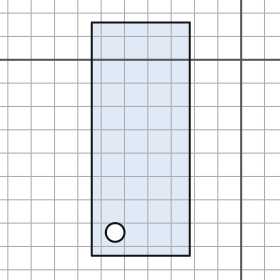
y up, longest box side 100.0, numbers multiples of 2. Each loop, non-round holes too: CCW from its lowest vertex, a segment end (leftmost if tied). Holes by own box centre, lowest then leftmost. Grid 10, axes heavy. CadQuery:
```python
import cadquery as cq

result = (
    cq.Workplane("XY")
    .moveTo(-64.0, -84.0)
    .lineTo(-22.0, -84.0)
    .lineTo(-22.0, 16.0)
    .lineTo(-64.0, 16.0)
    .close()
    .moveTo(-54.0, -74.0)
    .circle(4.0)
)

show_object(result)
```